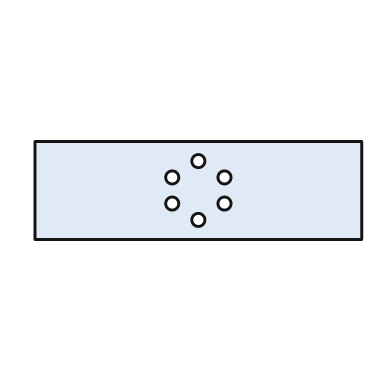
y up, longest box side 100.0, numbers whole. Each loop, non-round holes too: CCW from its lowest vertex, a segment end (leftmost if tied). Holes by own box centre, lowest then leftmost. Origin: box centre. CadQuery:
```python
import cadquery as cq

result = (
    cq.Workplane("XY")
    .moveTo(-50.0, -15.0)
    .lineTo(50.0, -15.0)
    .lineTo(50.0, 15.0)
    .lineTo(-50.0, 15.0)
    .close()
    .moveTo(0.0, -9.0)
    .circle(2.0)
    .moveTo(-8.0, -4.0)
    .circle(2.0)
    .moveTo(8.0, -4.0)
    .circle(2.0)
    .moveTo(-8.0, 4.0)
    .circle(2.0)
    .moveTo(8.0, 4.0)
    .circle(2.0)
    .moveTo(0.0, 9.0)
    .circle(2.0)
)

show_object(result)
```